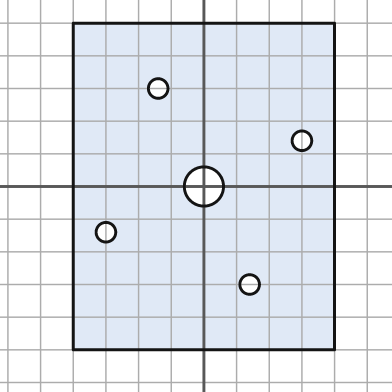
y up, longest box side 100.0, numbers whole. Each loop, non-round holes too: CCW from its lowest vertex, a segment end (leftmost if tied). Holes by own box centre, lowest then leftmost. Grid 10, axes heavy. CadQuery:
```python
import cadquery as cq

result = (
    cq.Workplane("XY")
    .moveTo(-40.0, -50.0)
    .lineTo(40.0, -50.0)
    .lineTo(40.0, 50.0)
    .lineTo(-40.0, 50.0)
    .close()
    .moveTo(14.0, -30.0)
    .circle(3.0)
    .moveTo(-30.0, -14.0)
    .circle(3.0)
    .moveTo(0.0, 0.0)
    .circle(6.0)
    .moveTo(30.0, 14.0)
    .circle(3.0)
    .moveTo(-14.0, 30.0)
    .circle(3.0)
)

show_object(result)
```